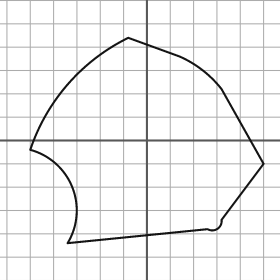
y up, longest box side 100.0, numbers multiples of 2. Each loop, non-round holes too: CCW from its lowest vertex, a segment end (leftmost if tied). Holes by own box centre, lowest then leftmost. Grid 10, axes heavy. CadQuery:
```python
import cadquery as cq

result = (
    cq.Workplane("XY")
    .moveTo(-34.0, -44.0)
    .lineTo(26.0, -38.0)
    .threePointArc((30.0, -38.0), (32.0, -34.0))
    .lineTo(50.0, -10.0)
    .lineTo(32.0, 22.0)
    .threePointArc((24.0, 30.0), (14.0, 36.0))
    .lineTo(-8.0, 44.0)
    .threePointArc((-34.0, 24.0), (-50.0, -4.0))
    .threePointArc((-32.0, -20.0), (-34.0, -44.0))
    .close()
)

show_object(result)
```